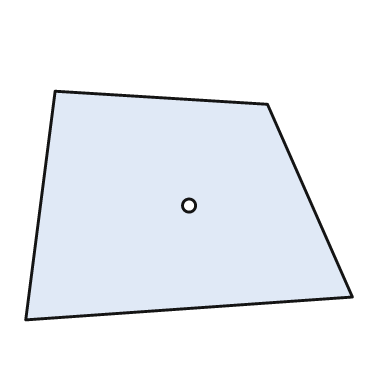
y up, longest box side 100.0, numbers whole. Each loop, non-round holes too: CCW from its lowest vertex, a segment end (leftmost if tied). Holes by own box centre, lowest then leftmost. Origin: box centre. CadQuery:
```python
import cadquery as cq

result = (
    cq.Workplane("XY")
    .moveTo(-50.0, -35.0)
    .lineTo(50.0, -28.0)
    .lineTo(24.0, 31.0)
    .lineTo(-41.0, 35.0)
    .close()
    .moveTo(0.0, 0.0)
    .circle(2.0)
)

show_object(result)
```